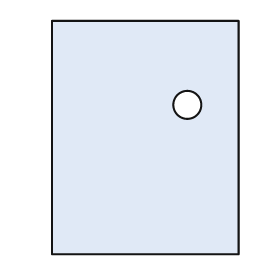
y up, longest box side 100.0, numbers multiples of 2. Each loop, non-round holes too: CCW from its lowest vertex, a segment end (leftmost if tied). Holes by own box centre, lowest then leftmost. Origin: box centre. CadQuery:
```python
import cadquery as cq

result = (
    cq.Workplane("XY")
    .moveTo(-40.0, -50.0)
    .lineTo(40.0, -50.0)
    .lineTo(40.0, 50.0)
    .lineTo(-40.0, 50.0)
    .close()
    .moveTo(18.0, 14.0)
    .circle(6.0)
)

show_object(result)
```